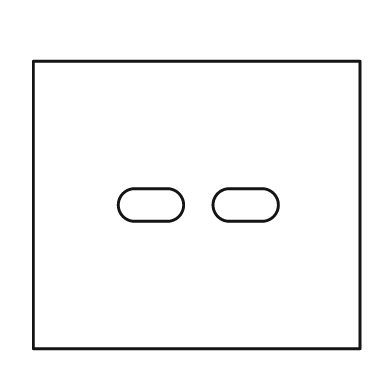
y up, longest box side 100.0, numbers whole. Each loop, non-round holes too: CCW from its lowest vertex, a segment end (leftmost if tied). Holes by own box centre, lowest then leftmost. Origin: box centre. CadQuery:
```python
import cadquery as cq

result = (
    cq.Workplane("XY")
    .moveTo(-50.0, -44.0)
    .lineTo(50.0, -44.0)
    .lineTo(50.0, 44.0)
    .lineTo(-50.0, 44.0)
    .close()
    .moveTo(-19.0, -5.0)
    .lineTo(-9.0, -5.0)
    .threePointArc((-4.0, 0.0), (-9.0, 5.0))
    .lineTo(-19.0, 5.0)
    .threePointArc((-24.0, 0.0), (-19.0, -5.0))
    .close()
    .moveTo(10.0, -5.0)
    .lineTo(20.0, -5.0)
    .threePointArc((25.0, 0.0), (20.0, 5.0))
    .lineTo(10.0, 5.0)
    .threePointArc((5.0, 0.0), (10.0, -5.0))
    .close()
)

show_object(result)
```